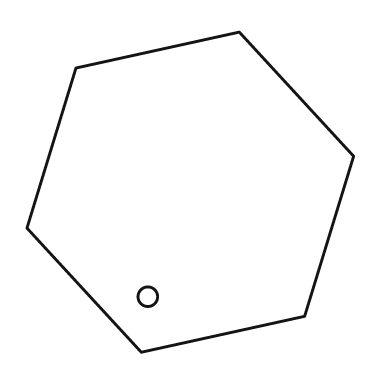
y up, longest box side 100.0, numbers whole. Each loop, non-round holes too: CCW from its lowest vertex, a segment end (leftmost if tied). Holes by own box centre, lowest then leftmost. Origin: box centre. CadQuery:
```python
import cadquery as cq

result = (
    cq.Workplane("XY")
    .moveTo(-15.0, -49.0)
    .lineTo(35.0, -38.0)
    .lineTo(50.0, 11.0)
    .lineTo(15.0, 49.0)
    .lineTo(-35.0, 38.0)
    .lineTo(-50.0, -11.0)
    .close()
    .moveTo(-13.0, -32.0)
    .circle(3.0)
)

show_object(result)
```